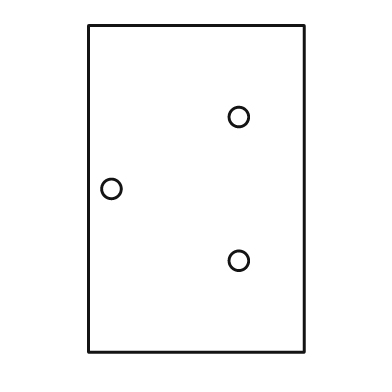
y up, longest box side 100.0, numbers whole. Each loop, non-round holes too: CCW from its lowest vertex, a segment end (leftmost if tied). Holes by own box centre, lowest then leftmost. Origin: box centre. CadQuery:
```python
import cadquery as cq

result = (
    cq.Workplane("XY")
    .moveTo(-33.0, -50.0)
    .lineTo(33.0, -50.0)
    .lineTo(33.0, 50.0)
    .lineTo(-33.0, 50.0)
    .close()
    .moveTo(13.0, -22.0)
    .circle(3.0)
    .moveTo(-26.0, 0.0)
    .circle(3.0)
    .moveTo(13.0, 22.0)
    .circle(3.0)
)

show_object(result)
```